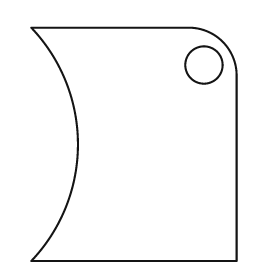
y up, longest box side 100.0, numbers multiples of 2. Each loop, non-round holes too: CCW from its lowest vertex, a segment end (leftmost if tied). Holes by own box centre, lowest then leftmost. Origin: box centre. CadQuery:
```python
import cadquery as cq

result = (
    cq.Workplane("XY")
    .moveTo(-44.0, -50.0)
    .lineTo(44.0, -50.0)
    .lineTo(44.0, 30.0)
    .threePointArc((38.0, 44.0), (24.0, 50.0))
    .lineTo(-44.0, 50.0)
    .threePointArc((-24.0, 0.0), (-44.0, -50.0))
    .close()
    .moveTo(30.0, 34.0)
    .circle(8.0)
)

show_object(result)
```